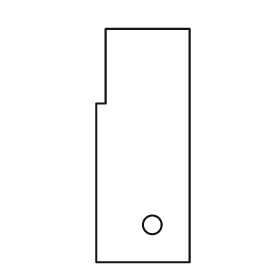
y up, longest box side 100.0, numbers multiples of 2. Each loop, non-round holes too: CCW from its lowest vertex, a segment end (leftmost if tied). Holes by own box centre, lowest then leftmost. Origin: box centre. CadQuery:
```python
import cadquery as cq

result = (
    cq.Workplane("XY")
    .moveTo(-20.0, -50.0)
    .lineTo(20.0, -50.0)
    .lineTo(20.0, 50.0)
    .lineTo(-16.0, 50.0)
    .lineTo(-16.0, 18.0)
    .lineTo(-20.0, 18.0)
    .close()
    .moveTo(4.0, -34.0)
    .circle(4.0)
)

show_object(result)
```